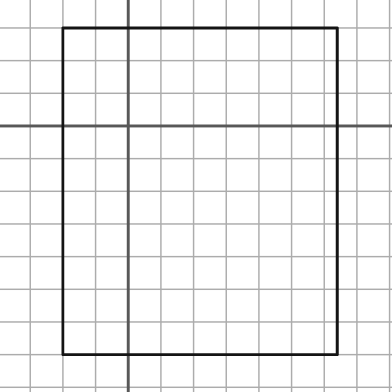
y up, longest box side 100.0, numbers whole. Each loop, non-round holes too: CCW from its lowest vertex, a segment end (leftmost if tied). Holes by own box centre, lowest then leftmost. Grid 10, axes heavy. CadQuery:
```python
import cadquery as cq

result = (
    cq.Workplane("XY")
    .moveTo(-20.0, -70.0)
    .lineTo(64.0, -70.0)
    .lineTo(64.0, 30.0)
    .lineTo(-20.0, 30.0)
    .close()
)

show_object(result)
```